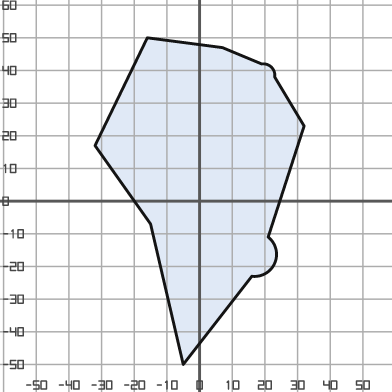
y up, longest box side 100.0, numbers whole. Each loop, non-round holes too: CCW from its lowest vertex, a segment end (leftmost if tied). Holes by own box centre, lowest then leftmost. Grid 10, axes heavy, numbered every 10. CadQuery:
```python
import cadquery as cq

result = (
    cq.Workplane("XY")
    .moveTo(-5.0, -50.0)
    .lineTo(16.0, -23.0)
    .threePointArc((23.0, -19.0), (21.0, -11.0))
    .lineTo(32.0, 23.0)
    .lineTo(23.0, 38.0)
    .threePointArc((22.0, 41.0), (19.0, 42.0))
    .lineTo(7.0, 47.0)
    .lineTo(-16.0, 50.0)
    .lineTo(-32.0, 17.0)
    .lineTo(-15.0, -7.0)
    .close()
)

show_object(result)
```